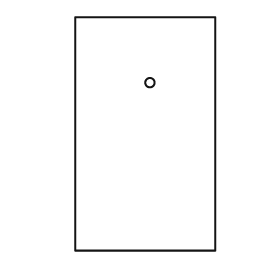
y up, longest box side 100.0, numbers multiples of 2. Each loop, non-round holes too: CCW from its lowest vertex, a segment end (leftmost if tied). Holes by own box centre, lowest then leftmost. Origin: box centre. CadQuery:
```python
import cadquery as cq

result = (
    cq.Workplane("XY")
    .moveTo(-30.0, -50.0)
    .lineTo(30.0, -50.0)
    .lineTo(30.0, 50.0)
    .lineTo(-30.0, 50.0)
    .close()
    .moveTo(2.0, 22.0)
    .circle(2.0)
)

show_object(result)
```